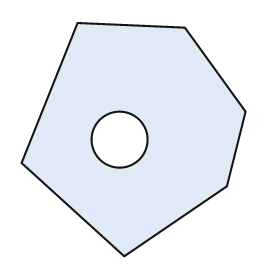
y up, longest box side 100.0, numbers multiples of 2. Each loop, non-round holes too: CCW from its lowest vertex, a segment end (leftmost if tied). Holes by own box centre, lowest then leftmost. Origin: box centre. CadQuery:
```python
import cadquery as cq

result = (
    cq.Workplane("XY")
    .moveTo(-4.0, -50.0)
    .lineTo(40.0, -20.0)
    .lineTo(48.0, 12.0)
    .lineTo(22.0, 48.0)
    .lineTo(-24.0, 50.0)
    .lineTo(-48.0, -10.0)
    .close()
    .moveTo(-6.0, 0.0)
    .circle(12.0)
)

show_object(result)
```